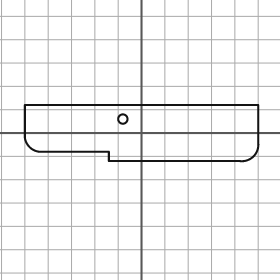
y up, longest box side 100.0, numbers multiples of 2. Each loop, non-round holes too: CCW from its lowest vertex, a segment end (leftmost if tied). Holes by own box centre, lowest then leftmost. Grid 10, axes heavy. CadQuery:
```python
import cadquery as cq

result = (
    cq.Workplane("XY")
    .moveTo(-14.0, -12.0)
    .lineTo(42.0, -12.0)
    .threePointArc((48.0, -10.0), (50.0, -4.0))
    .lineTo(50.0, 12.0)
    .lineTo(-50.0, 12.0)
    .lineTo(-50.0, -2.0)
    .threePointArc((-48.0, -6.0), (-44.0, -8.0))
    .lineTo(-14.0, -8.0)
    .close()
    .moveTo(-8.0, 6.0)
    .circle(2.0)
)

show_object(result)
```